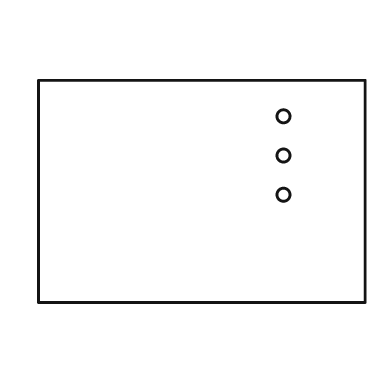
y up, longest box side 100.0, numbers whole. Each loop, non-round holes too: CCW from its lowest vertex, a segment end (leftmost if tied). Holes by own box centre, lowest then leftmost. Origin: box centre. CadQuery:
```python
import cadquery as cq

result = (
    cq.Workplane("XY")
    .moveTo(-50.0, -34.0)
    .lineTo(50.0, -34.0)
    .lineTo(50.0, 34.0)
    .lineTo(-50.0, 34.0)
    .close()
    .moveTo(25.0, -1.0)
    .circle(2.0)
    .moveTo(25.0, 11.0)
    .circle(2.0)
    .moveTo(25.0, 23.0)
    .circle(2.0)
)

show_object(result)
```